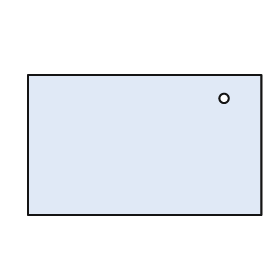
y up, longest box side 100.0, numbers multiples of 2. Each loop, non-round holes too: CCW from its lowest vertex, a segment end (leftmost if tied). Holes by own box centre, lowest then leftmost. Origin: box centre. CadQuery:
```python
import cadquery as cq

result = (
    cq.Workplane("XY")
    .moveTo(-50.0, -30.0)
    .lineTo(50.0, -30.0)
    .lineTo(50.0, 30.0)
    .lineTo(-50.0, 30.0)
    .close()
    .moveTo(34.0, 20.0)
    .circle(2.0)
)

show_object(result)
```